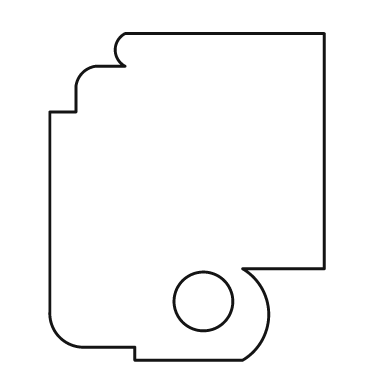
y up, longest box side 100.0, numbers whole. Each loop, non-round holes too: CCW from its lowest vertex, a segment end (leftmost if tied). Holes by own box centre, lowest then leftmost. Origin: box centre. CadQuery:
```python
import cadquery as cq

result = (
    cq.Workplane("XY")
    .moveTo(-16.0, -50.0)
    .lineTo(17.0, -50.0)
    .threePointArc((25.0, -36.0), (17.0, -22.0))
    .lineTo(42.0, -22.0)
    .lineTo(42.0, 50.0)
    .lineTo(-19.0, 50.0)
    .threePointArc((-22.0, 45.0), (-19.0, 40.0))
    .lineTo(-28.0, 40.0)
    .threePointArc((-32.0, 38.0), (-34.0, 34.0))
    .lineTo(-34.0, 26.0)
    .lineTo(-42.0, 26.0)
    .lineTo(-42.0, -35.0)
    .threePointArc((-39.0, -43.0), (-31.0, -46.0))
    .lineTo(-16.0, -46.0)
    .close()
    .moveTo(5.0, -32.0)
    .circle(9.0)
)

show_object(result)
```